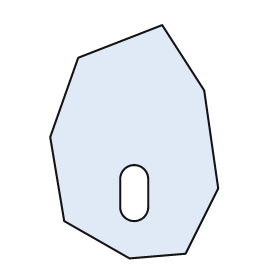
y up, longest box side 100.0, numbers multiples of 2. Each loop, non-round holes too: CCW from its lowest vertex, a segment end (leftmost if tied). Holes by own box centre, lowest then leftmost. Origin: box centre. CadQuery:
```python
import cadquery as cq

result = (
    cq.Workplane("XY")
    .moveTo(-2.0, -50.0)
    .lineTo(22.0, -48.0)
    .lineTo(36.0, -20.0)
    .lineTo(30.0, 22.0)
    .lineTo(12.0, 50.0)
    .lineTo(-24.0, 36.0)
    .lineTo(-36.0, 2.0)
    .lineTo(-30.0, -34.0)
    .close()
    .moveTo(-6.0, -28.0)
    .threePointArc((0.0, -34.0), (6.0, -28.0))
    .lineTo(6.0, -16.0)
    .threePointArc((0.0, -10.0), (-6.0, -16.0))
    .close()
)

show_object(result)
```